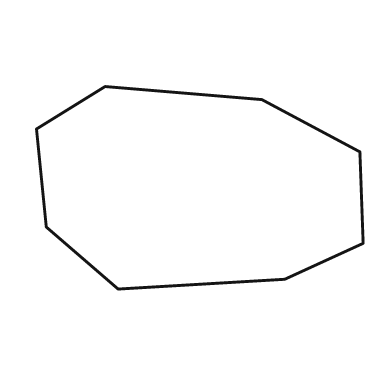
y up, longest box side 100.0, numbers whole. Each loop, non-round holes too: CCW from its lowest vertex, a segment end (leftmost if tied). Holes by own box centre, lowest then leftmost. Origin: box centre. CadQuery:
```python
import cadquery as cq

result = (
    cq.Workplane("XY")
    .moveTo(-25.0, -31.0)
    .lineTo(26.0, -28.0)
    .lineTo(50.0, -17.0)
    .lineTo(49.0, 11.0)
    .lineTo(19.0, 27.0)
    .lineTo(-29.0, 31.0)
    .lineTo(-50.0, 18.0)
    .lineTo(-47.0, -12.0)
    .close()
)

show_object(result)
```